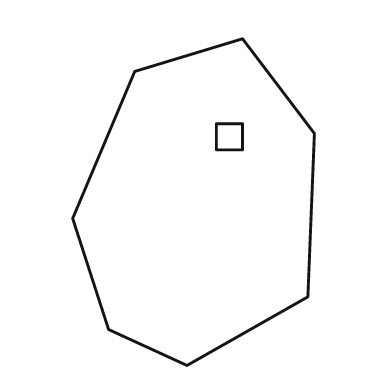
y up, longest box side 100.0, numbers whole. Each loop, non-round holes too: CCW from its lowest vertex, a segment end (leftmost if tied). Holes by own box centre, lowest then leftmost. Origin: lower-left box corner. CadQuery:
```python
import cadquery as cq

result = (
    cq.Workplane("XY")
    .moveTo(35.0, 0.0)
    .lineTo(72.0, 21.0)
    .lineTo(74.0, 71.0)
    .lineTo(52.0, 100.0)
    .lineTo(19.0, 90.0)
    .lineTo(0.0, 45.0)
    .lineTo(11.0, 11.0)
    .close()
    .moveTo(44.0, 66.0)
    .lineTo(52.0, 66.0)
    .lineTo(52.0, 74.0)
    .lineTo(44.0, 74.0)
    .close()
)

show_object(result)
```